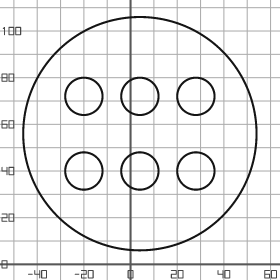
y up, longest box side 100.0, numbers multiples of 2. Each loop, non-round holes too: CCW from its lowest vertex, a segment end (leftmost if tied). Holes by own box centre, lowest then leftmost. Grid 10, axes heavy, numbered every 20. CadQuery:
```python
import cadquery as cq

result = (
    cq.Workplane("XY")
    .moveTo(4.0, 56.0)
    .circle(50.0)
    .moveTo(-20.0, 40.0)
    .circle(8.0)
    .moveTo(4.0, 40.0)
    .circle(8.0)
    .moveTo(28.0, 40.0)
    .circle(8.0)
    .moveTo(-20.0, 72.0)
    .circle(8.0)
    .moveTo(4.0, 72.0)
    .circle(8.0)
    .moveTo(28.0, 72.0)
    .circle(8.0)
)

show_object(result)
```